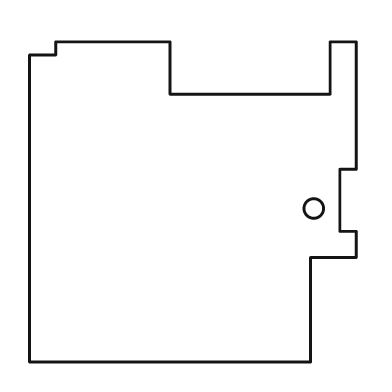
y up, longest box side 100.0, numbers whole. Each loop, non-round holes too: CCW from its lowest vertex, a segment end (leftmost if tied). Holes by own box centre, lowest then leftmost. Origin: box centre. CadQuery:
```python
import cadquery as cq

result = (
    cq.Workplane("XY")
    .moveTo(-50.0, -49.0)
    .lineTo(36.0, -49.0)
    .lineTo(36.0, -17.0)
    .lineTo(50.0, -17.0)
    .lineTo(50.0, -9.0)
    .lineTo(45.0, -9.0)
    .lineTo(45.0, 10.0)
    .lineTo(50.0, 10.0)
    .lineTo(50.0, 49.0)
    .lineTo(42.0, 49.0)
    .lineTo(42.0, 33.0)
    .lineTo(-7.0, 33.0)
    .lineTo(-7.0, 49.0)
    .lineTo(-42.0, 49.0)
    .lineTo(-42.0, 45.0)
    .lineTo(-50.0, 45.0)
    .close()
    .moveTo(37.0, -2.0)
    .circle(3.0)
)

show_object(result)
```